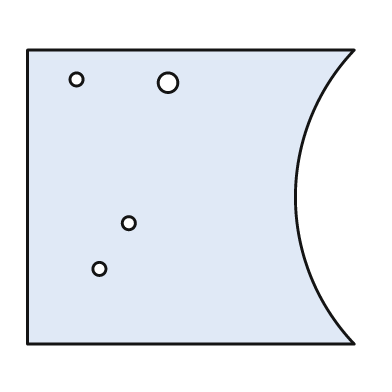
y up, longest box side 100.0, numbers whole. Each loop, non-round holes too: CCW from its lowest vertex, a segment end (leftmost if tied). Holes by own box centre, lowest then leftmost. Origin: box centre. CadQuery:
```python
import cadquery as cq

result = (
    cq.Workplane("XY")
    .moveTo(-50.0, -45.0)
    .lineTo(50.0, -45.0)
    .threePointArc((32.0, 0.0), (50.0, 45.0))
    .lineTo(-50.0, 45.0)
    .close()
    .moveTo(-28.0, -22.0)
    .circle(2.0)
    .moveTo(-19.0, -8.0)
    .circle(2.0)
    .moveTo(-7.0, 35.0)
    .circle(3.0)
    .moveTo(-35.0, 36.0)
    .circle(2.0)
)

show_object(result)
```